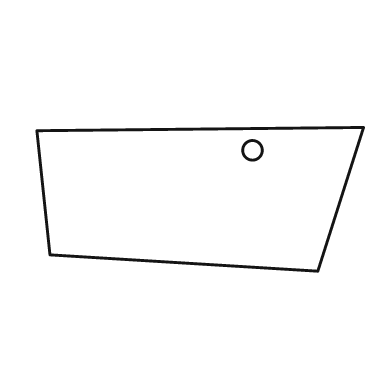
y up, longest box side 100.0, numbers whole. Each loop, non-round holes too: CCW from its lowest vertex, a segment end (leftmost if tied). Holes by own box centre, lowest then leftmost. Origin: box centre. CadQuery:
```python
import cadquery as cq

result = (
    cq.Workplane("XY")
    .moveTo(36.0, -22.0)
    .lineTo(50.0, 22.0)
    .lineTo(-50.0, 21.0)
    .lineTo(-46.0, -17.0)
    .close()
    .moveTo(16.0, 15.0)
    .circle(3.0)
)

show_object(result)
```